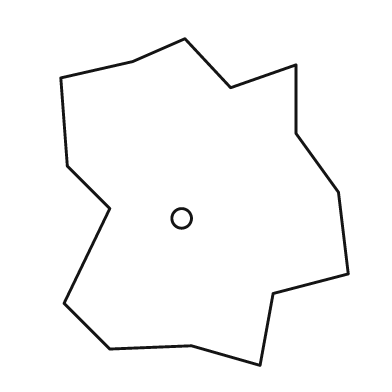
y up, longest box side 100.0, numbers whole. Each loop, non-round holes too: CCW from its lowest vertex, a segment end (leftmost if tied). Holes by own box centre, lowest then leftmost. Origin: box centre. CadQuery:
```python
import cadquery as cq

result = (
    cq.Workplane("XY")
    .moveTo(17.0, -50.0)
    .lineTo(21.0, -28.0)
    .lineTo(44.0, -22.0)
    .lineTo(41.0, 3.0)
    .lineTo(28.0, 21.0)
    .lineTo(28.0, 42.0)
    .lineTo(8.0, 35.0)
    .lineTo(-6.0, 50.0)
    .lineTo(-22.0, 43.0)
    .lineTo(-44.0, 38.0)
    .lineTo(-42.0, 11.0)
    .lineTo(-29.0, -2.0)
    .lineTo(-43.0, -31.0)
    .lineTo(-29.0, -45.0)
    .lineTo(-4.0, -44.0)
    .close()
    .moveTo(-7.0, -5.0)
    .circle(3.0)
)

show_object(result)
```